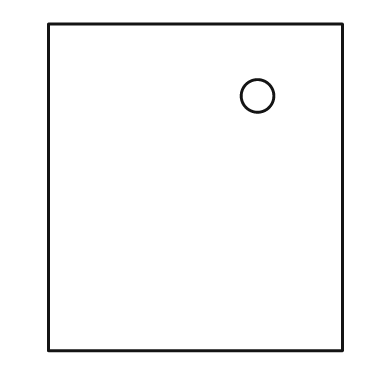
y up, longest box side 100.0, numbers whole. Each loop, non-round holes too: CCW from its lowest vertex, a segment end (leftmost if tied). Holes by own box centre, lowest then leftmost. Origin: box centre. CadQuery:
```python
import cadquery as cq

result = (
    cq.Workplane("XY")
    .moveTo(-45.0, -50.0)
    .lineTo(45.0, -50.0)
    .lineTo(45.0, 50.0)
    .lineTo(-45.0, 50.0)
    .close()
    .moveTo(19.0, 28.0)
    .circle(5.0)
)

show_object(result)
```